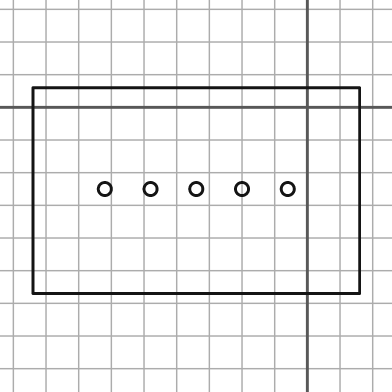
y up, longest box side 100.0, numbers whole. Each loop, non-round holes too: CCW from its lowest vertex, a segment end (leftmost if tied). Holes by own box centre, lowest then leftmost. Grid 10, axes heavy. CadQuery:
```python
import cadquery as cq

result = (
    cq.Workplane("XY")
    .moveTo(-84.0, -57.0)
    .lineTo(16.0, -57.0)
    .lineTo(16.0, 6.0)
    .lineTo(-84.0, 6.0)
    .close()
    .moveTo(-62.0, -25.0)
    .circle(2.0)
    .moveTo(-48.0, -25.0)
    .circle(2.0)
    .moveTo(-34.0, -25.0)
    .circle(2.0)
    .moveTo(-20.0, -25.0)
    .circle(2.0)
    .moveTo(-6.0, -25.0)
    .circle(2.0)
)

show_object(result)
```